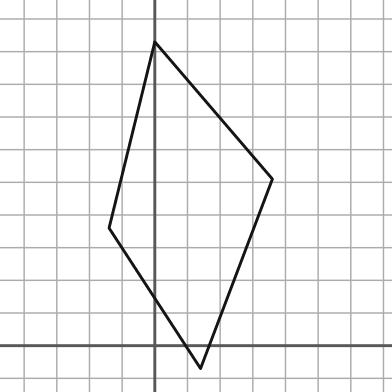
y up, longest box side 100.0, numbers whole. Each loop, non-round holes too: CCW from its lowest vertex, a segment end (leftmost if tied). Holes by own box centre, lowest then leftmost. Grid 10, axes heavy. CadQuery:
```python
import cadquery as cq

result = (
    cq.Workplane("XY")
    .moveTo(14.0, -7.0)
    .lineTo(36.0, 51.0)
    .lineTo(0.0, 93.0)
    .lineTo(-14.0, 36.0)
    .close()
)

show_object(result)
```